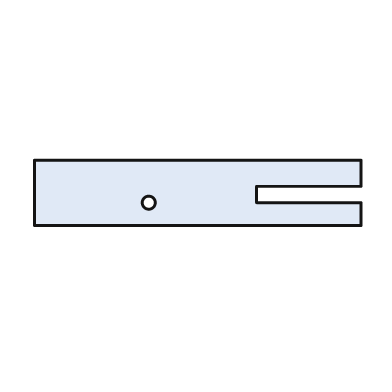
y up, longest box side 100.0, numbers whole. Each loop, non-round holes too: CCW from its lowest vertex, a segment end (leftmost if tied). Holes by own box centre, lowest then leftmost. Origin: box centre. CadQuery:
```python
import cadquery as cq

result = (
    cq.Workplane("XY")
    .moveTo(-50.0, -10.0)
    .lineTo(50.0, -10.0)
    .lineTo(50.0, -3.0)
    .lineTo(18.0, -3.0)
    .lineTo(18.0, 2.0)
    .lineTo(50.0, 2.0)
    .lineTo(50.0, 10.0)
    .lineTo(-50.0, 10.0)
    .close()
    .moveTo(-15.0, -3.0)
    .circle(2.0)
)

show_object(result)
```